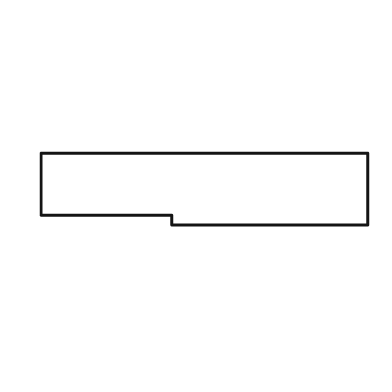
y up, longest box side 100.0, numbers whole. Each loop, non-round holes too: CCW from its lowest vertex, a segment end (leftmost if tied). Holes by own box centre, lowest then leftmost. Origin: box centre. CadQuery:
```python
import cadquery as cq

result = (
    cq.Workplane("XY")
    .moveTo(-10.0, -11.0)
    .lineTo(50.0, -11.0)
    .lineTo(50.0, 11.0)
    .lineTo(-50.0, 11.0)
    .lineTo(-50.0, -8.0)
    .lineTo(-10.0, -8.0)
    .close()
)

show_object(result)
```